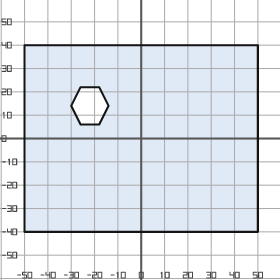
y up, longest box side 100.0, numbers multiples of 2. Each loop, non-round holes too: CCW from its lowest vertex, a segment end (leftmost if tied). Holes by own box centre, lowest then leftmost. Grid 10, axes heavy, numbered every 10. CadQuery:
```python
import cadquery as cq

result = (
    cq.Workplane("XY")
    .moveTo(-50.0, -40.0)
    .lineTo(50.0, -40.0)
    .lineTo(50.0, 40.0)
    .lineTo(-50.0, 40.0)
    .close()
    .moveTo(-26.0, 6.0)
    .lineTo(-18.0, 6.0)
    .lineTo(-14.0, 14.0)
    .lineTo(-18.0, 22.0)
    .lineTo(-26.0, 22.0)
    .lineTo(-30.0, 14.0)
    .close()
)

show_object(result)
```